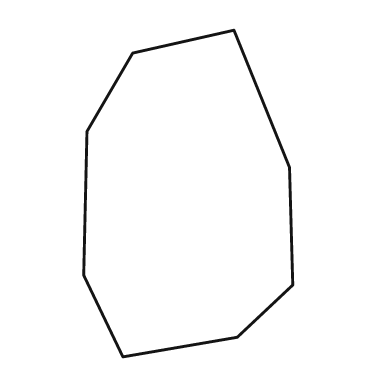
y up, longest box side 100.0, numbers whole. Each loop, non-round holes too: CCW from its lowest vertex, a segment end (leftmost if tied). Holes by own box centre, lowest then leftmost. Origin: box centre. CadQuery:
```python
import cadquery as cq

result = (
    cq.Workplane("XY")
    .moveTo(-20.0, -50.0)
    .lineTo(15.0, -44.0)
    .lineTo(32.0, -28.0)
    .lineTo(31.0, 8.0)
    .lineTo(14.0, 50.0)
    .lineTo(-17.0, 43.0)
    .lineTo(-31.0, 19.0)
    .lineTo(-32.0, -25.0)
    .close()
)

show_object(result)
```